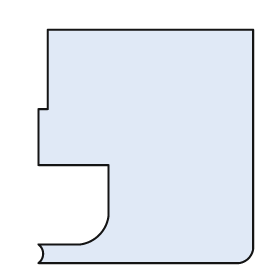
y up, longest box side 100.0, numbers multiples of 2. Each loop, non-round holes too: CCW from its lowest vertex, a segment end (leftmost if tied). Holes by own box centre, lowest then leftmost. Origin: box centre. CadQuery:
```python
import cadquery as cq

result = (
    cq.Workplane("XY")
    .moveTo(-46.0, -50.0)
    .lineTo(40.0, -50.0)
    .threePointArc((44.0, -48.0), (46.0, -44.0))
    .lineTo(46.0, 50.0)
    .lineTo(-42.0, 50.0)
    .lineTo(-42.0, 16.0)
    .lineTo(-46.0, 16.0)
    .lineTo(-46.0, -8.0)
    .lineTo(-16.0, -8.0)
    .lineTo(-16.0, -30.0)
    .threePointArc((-20.0, -38.0), (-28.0, -42.0))
    .lineTo(-46.0, -42.0)
    .threePointArc((-44.0, -46.0), (-46.0, -50.0))
    .close()
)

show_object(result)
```